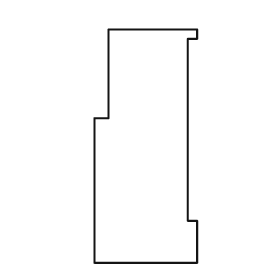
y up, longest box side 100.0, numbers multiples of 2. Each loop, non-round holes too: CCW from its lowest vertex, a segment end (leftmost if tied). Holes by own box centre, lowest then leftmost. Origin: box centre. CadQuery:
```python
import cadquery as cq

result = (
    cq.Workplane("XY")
    .moveTo(-22.0, -50.0)
    .lineTo(22.0, -50.0)
    .lineTo(22.0, -32.0)
    .lineTo(18.0, -32.0)
    .lineTo(18.0, 46.0)
    .lineTo(22.0, 46.0)
    .lineTo(22.0, 50.0)
    .lineTo(-16.0, 50.0)
    .lineTo(-16.0, 12.0)
    .lineTo(-22.0, 12.0)
    .close()
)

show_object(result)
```